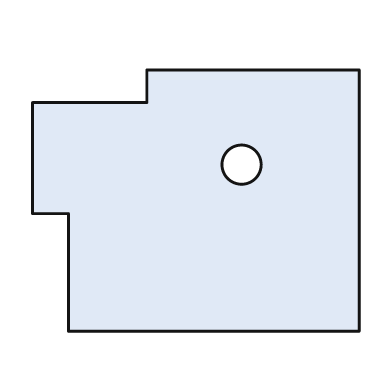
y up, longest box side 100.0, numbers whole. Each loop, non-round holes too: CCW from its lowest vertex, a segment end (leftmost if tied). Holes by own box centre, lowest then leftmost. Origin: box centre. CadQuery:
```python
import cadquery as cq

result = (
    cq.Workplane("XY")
    .moveTo(-39.0, -40.0)
    .lineTo(50.0, -40.0)
    .lineTo(50.0, 40.0)
    .lineTo(-15.0, 40.0)
    .lineTo(-15.0, 30.0)
    .lineTo(-50.0, 30.0)
    .lineTo(-50.0, -4.0)
    .lineTo(-39.0, -4.0)
    .close()
    .moveTo(14.0, 11.0)
    .circle(6.0)
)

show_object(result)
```